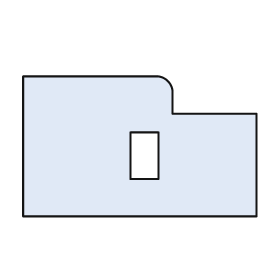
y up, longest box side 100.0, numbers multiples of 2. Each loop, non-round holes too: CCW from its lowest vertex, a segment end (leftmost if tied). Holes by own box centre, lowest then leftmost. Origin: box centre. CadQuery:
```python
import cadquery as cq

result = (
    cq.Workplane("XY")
    .moveTo(-50.0, -30.0)
    .lineTo(50.0, -30.0)
    .lineTo(50.0, 14.0)
    .lineTo(14.0, 14.0)
    .lineTo(14.0, 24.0)
    .threePointArc((12.0, 28.0), (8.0, 30.0))
    .lineTo(-50.0, 30.0)
    .close()
    .moveTo(-4.0, -14.0)
    .lineTo(8.0, -14.0)
    .lineTo(8.0, 6.0)
    .lineTo(-4.0, 6.0)
    .close()
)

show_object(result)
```